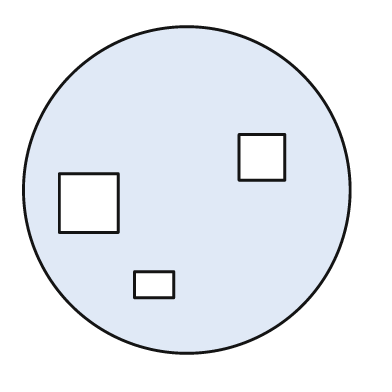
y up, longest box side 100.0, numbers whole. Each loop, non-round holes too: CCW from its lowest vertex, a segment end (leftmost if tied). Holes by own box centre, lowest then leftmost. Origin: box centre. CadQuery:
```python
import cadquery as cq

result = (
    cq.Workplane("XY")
    .moveTo(0.0, 0.0)
    .circle(50.0)
    .moveTo(-16.0, -33.0)
    .lineTo(-4.0, -33.0)
    .lineTo(-4.0, -25.0)
    .lineTo(-16.0, -25.0)
    .close()
    .moveTo(-39.0, -13.0)
    .lineTo(-21.0, -13.0)
    .lineTo(-21.0, 5.0)
    .lineTo(-39.0, 5.0)
    .close()
    .moveTo(16.0, 3.0)
    .lineTo(30.0, 3.0)
    .lineTo(30.0, 17.0)
    .lineTo(16.0, 17.0)
    .close()
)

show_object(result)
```